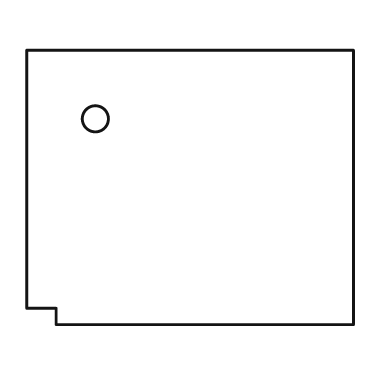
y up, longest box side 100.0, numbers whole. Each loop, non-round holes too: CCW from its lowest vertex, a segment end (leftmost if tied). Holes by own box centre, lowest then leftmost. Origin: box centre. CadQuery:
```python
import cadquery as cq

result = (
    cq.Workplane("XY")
    .moveTo(-41.0, -42.0)
    .lineTo(50.0, -42.0)
    .lineTo(50.0, 42.0)
    .lineTo(-50.0, 42.0)
    .lineTo(-50.0, -37.0)
    .lineTo(-41.0, -37.0)
    .close()
    .moveTo(-29.0, 21.0)
    .circle(4.0)
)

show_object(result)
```